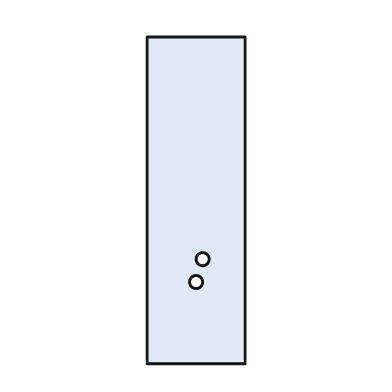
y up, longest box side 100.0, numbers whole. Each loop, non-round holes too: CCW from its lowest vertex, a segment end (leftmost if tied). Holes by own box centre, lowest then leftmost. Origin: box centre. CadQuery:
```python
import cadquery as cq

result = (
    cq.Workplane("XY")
    .moveTo(-15.0, -50.0)
    .lineTo(15.0, -50.0)
    .lineTo(15.0, 50.0)
    .lineTo(-15.0, 50.0)
    .close()
    .moveTo(0.0, -25.0)
    .circle(2.0)
    .moveTo(2.0, -18.0)
    .circle(2.0)
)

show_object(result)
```